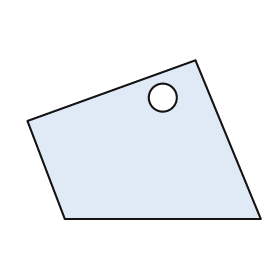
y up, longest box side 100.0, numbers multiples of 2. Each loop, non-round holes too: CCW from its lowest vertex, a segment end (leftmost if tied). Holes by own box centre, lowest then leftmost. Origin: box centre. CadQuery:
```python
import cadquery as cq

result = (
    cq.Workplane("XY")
    .moveTo(-34.0, -34.0)
    .lineTo(50.0, -34.0)
    .lineTo(22.0, 34.0)
    .lineTo(-50.0, 8.0)
    .close()
    .moveTo(8.0, 18.0)
    .circle(6.0)
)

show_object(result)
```